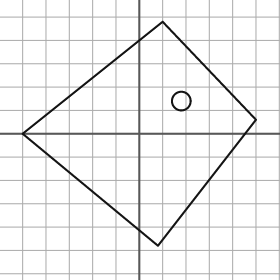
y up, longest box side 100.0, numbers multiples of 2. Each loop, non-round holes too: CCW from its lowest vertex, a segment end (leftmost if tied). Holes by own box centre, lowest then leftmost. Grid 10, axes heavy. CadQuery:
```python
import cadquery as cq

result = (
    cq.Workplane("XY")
    .moveTo(8.0, -48.0)
    .lineTo(50.0, 6.0)
    .lineTo(10.0, 48.0)
    .lineTo(-50.0, 0.0)
    .close()
    .moveTo(18.0, 14.0)
    .circle(4.0)
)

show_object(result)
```